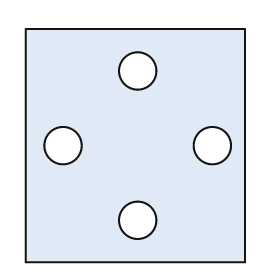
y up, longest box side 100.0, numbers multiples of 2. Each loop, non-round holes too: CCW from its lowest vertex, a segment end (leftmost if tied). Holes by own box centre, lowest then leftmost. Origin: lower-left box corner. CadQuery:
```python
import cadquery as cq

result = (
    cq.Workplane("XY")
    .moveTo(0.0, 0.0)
    .lineTo(94.0, 0.0)
    .lineTo(94.0, 100.0)
    .lineTo(0.0, 100.0)
    .close()
    .moveTo(48.0, 18.0)
    .circle(8.0)
    .moveTo(16.0, 50.0)
    .circle(8.0)
    .moveTo(80.0, 50.0)
    .circle(8.0)
    .moveTo(48.0, 82.0)
    .circle(8.0)
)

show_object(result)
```